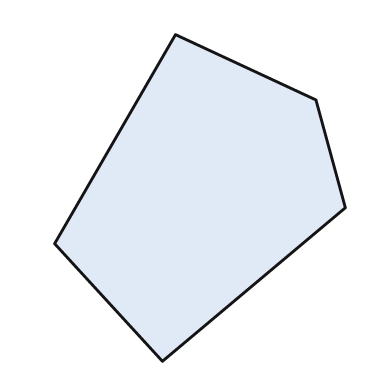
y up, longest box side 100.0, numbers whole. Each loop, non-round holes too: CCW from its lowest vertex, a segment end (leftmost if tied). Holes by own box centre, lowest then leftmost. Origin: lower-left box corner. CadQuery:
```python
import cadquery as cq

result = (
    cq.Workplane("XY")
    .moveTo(33.0, 0.0)
    .lineTo(89.0, 47.0)
    .lineTo(80.0, 80.0)
    .lineTo(37.0, 100.0)
    .lineTo(0.0, 36.0)
    .close()
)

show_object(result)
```